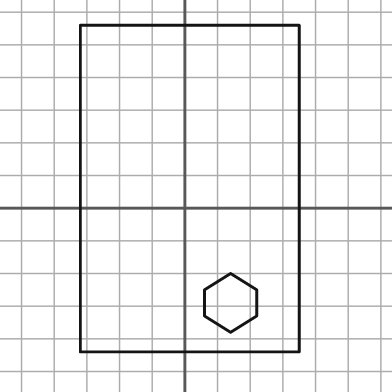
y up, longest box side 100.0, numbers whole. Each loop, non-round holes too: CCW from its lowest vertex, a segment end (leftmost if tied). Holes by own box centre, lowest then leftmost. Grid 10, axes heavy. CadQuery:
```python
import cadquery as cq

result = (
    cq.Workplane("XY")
    .moveTo(-32.0, -44.0)
    .lineTo(35.0, -44.0)
    .lineTo(35.0, 56.0)
    .lineTo(-32.0, 56.0)
    .close()
    .moveTo(14.0, -38.0)
    .lineTo(22.0, -33.0)
    .lineTo(22.0, -25.0)
    .lineTo(14.0, -20.0)
    .lineTo(6.0, -25.0)
    .lineTo(6.0, -33.0)
    .close()
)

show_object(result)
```